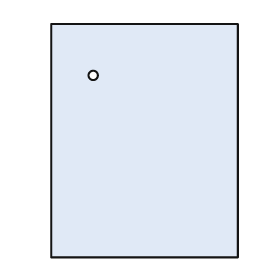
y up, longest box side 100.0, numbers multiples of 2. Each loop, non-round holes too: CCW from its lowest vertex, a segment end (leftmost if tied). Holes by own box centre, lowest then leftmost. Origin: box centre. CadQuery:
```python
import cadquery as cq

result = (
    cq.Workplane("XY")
    .moveTo(-40.0, -50.0)
    .lineTo(40.0, -50.0)
    .lineTo(40.0, 50.0)
    .lineTo(-40.0, 50.0)
    .close()
    .moveTo(-22.0, 28.0)
    .circle(2.0)
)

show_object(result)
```